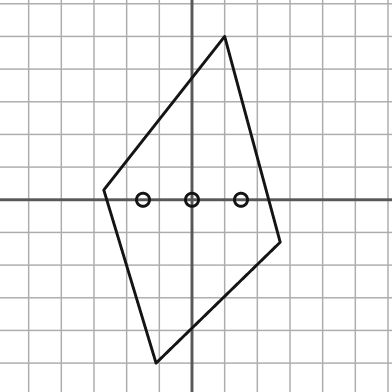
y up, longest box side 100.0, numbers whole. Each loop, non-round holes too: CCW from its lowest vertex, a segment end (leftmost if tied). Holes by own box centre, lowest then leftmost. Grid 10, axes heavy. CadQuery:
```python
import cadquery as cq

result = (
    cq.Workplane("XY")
    .moveTo(-11.0, -50.0)
    .lineTo(27.0, -13.0)
    .lineTo(10.0, 50.0)
    .lineTo(-27.0, 3.0)
    .close()
    .moveTo(-15.0, 0.0)
    .circle(2.0)
    .moveTo(0.0, 0.0)
    .circle(2.0)
    .moveTo(15.0, 0.0)
    .circle(2.0)
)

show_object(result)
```